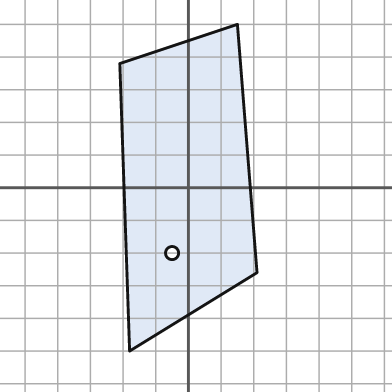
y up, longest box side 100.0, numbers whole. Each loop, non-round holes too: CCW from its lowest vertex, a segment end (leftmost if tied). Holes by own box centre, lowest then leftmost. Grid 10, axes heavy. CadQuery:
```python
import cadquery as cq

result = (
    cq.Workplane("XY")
    .moveTo(-18.0, -50.0)
    .lineTo(21.0, -26.0)
    .lineTo(15.0, 50.0)
    .lineTo(-21.0, 38.0)
    .close()
    .moveTo(-5.0, -20.0)
    .circle(2.0)
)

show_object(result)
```